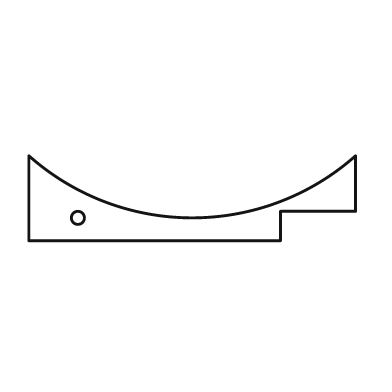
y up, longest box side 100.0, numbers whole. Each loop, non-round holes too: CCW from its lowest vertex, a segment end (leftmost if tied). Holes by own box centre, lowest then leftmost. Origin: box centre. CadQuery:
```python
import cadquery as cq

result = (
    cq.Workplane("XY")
    .moveTo(-50.0, -13.0)
    .lineTo(27.0, -13.0)
    .lineTo(27.0, -4.0)
    .lineTo(50.0, -4.0)
    .lineTo(50.0, 13.0)
    .threePointArc((0.0, -6.0), (-50.0, 13.0))
    .close()
    .moveTo(-35.0, -6.0)
    .circle(2.0)
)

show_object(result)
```